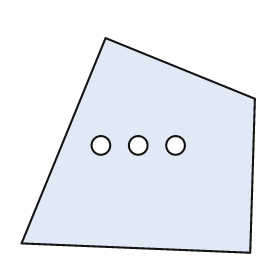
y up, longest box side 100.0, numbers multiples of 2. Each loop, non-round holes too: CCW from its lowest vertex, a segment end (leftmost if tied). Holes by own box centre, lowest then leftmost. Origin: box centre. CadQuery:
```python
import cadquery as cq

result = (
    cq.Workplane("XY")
    .moveTo(48.0, -46.0)
    .lineTo(50.0, 20.0)
    .lineTo(-14.0, 46.0)
    .lineTo(-50.0, -42.0)
    .close()
    .moveTo(-16.0, 0.0)
    .circle(4.0)
    .moveTo(0.0, 0.0)
    .circle(4.0)
    .moveTo(16.0, 0.0)
    .circle(4.0)
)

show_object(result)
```